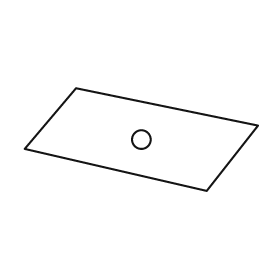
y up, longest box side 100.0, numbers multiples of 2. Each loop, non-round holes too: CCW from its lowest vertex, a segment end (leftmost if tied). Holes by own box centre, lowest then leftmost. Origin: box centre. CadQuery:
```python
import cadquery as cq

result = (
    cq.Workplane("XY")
    .moveTo(28.0, -22.0)
    .lineTo(50.0, 6.0)
    .lineTo(-28.0, 22.0)
    .lineTo(-50.0, -4.0)
    .close()
    .moveTo(0.0, 0.0)
    .circle(4.0)
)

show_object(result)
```